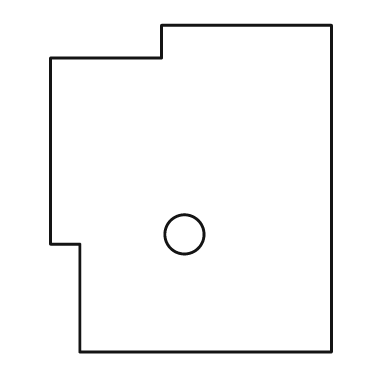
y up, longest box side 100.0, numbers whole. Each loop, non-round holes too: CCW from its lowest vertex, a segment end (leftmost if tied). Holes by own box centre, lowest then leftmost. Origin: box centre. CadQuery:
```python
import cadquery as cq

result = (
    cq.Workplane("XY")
    .moveTo(-34.0, -50.0)
    .lineTo(43.0, -50.0)
    .lineTo(43.0, 50.0)
    .lineTo(-9.0, 50.0)
    .lineTo(-9.0, 40.0)
    .lineTo(-43.0, 40.0)
    .lineTo(-43.0, -17.0)
    .lineTo(-34.0, -17.0)
    .close()
    .moveTo(-2.0, -14.0)
    .circle(6.0)
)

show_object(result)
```